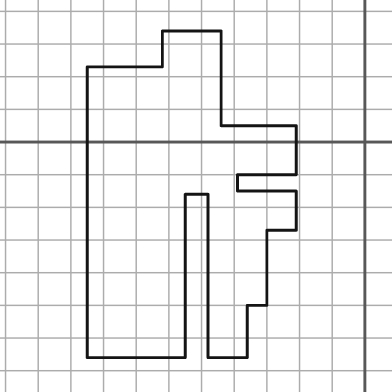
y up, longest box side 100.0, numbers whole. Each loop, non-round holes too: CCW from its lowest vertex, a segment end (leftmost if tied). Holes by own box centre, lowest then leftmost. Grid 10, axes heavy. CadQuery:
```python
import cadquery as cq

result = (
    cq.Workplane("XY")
    .moveTo(-85.0, -66.0)
    .lineTo(-55.0, -66.0)
    .lineTo(-55.0, -16.0)
    .lineTo(-48.0, -16.0)
    .lineTo(-48.0, -66.0)
    .lineTo(-36.0, -66.0)
    .lineTo(-36.0, -50.0)
    .lineTo(-30.0, -50.0)
    .lineTo(-30.0, -27.0)
    .lineTo(-21.0, -27.0)
    .lineTo(-21.0, -15.0)
    .lineTo(-39.0, -15.0)
    .lineTo(-39.0, -10.0)
    .lineTo(-21.0, -10.0)
    .lineTo(-21.0, 5.0)
    .lineTo(-44.0, 5.0)
    .lineTo(-44.0, 34.0)
    .lineTo(-62.0, 34.0)
    .lineTo(-62.0, 23.0)
    .lineTo(-85.0, 23.0)
    .close()
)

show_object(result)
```